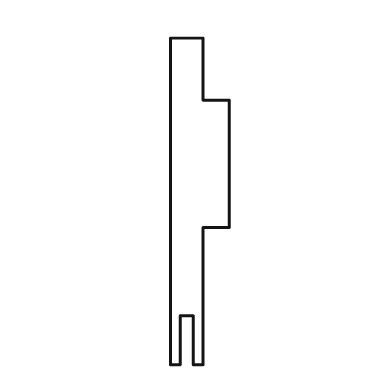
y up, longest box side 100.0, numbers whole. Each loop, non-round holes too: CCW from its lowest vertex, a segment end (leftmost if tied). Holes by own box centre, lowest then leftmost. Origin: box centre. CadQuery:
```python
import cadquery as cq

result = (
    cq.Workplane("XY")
    .moveTo(-9.0, -50.0)
    .lineTo(-6.0, -50.0)
    .lineTo(-6.0, -35.0)
    .lineTo(-2.0, -35.0)
    .lineTo(-2.0, -50.0)
    .lineTo(1.0, -50.0)
    .lineTo(1.0, -8.0)
    .lineTo(9.0, -8.0)
    .lineTo(9.0, 31.0)
    .lineTo(1.0, 31.0)
    .lineTo(1.0, 50.0)
    .lineTo(-9.0, 50.0)
    .close()
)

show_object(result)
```